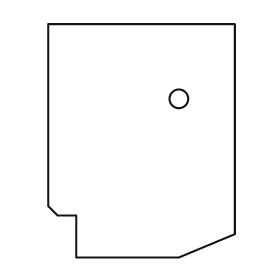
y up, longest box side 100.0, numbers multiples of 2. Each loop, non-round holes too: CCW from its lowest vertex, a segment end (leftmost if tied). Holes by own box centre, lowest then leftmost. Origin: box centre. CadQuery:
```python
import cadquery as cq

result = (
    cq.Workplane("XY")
    .moveTo(-28.0, -50.0)
    .lineTo(16.0, -50.0)
    .lineTo(40.0, -40.0)
    .lineTo(40.0, 50.0)
    .lineTo(-40.0, 50.0)
    .lineTo(-40.0, -28.0)
    .lineTo(-36.0, -32.0)
    .lineTo(-28.0, -32.0)
    .close()
    .moveTo(16.0, 18.0)
    .circle(4.0)
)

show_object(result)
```